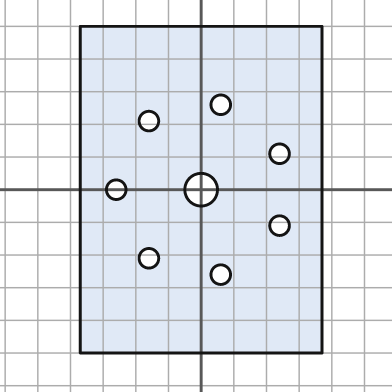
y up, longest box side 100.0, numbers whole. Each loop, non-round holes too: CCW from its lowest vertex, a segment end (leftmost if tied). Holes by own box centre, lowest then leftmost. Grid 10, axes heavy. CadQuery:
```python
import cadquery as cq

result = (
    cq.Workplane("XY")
    .moveTo(-37.0, -50.0)
    .lineTo(37.0, -50.0)
    .lineTo(37.0, 50.0)
    .lineTo(-37.0, 50.0)
    .close()
    .moveTo(6.0, -26.0)
    .circle(3.0)
    .moveTo(-16.0, -21.0)
    .circle(3.0)
    .moveTo(24.0, -11.0)
    .circle(3.0)
    .moveTo(-26.0, 0.0)
    .circle(3.0)
    .moveTo(0.0, 0.0)
    .circle(5.0)
    .moveTo(24.0, 11.0)
    .circle(3.0)
    .moveTo(-16.0, 21.0)
    .circle(3.0)
    .moveTo(6.0, 26.0)
    .circle(3.0)
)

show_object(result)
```